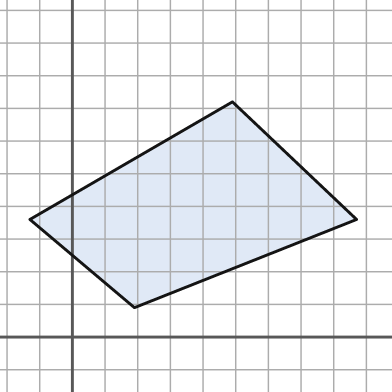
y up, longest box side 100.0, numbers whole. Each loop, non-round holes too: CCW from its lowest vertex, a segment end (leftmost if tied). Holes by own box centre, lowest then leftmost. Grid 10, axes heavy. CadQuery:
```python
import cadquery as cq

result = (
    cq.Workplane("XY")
    .moveTo(19.0, 9.0)
    .lineTo(87.0, 36.0)
    .lineTo(49.0, 72.0)
    .lineTo(-13.0, 36.0)
    .close()
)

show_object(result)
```